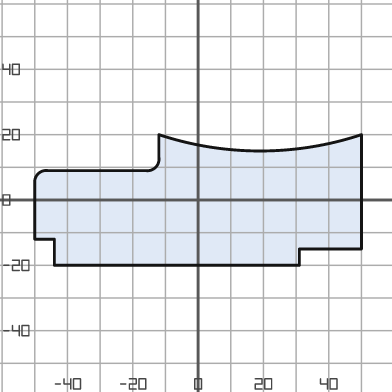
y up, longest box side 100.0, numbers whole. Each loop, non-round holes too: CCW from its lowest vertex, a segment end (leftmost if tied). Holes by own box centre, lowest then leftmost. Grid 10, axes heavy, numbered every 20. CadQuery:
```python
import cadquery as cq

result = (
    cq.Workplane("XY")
    .moveTo(-44.0, -20.0)
    .lineTo(31.0, -20.0)
    .lineTo(31.0, -15.0)
    .lineTo(50.0, -15.0)
    .lineTo(50.0, 20.0)
    .threePointArc((19.0, 15.0), (-12.0, 20.0))
    .lineTo(-12.0, 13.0)
    .threePointArc((-13.0, 10.0), (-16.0, 9.0))
    .lineTo(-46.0, 9.0)
    .threePointArc((-49.0, 8.0), (-50.0, 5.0))
    .lineTo(-50.0, -12.0)
    .lineTo(-44.0, -12.0)
    .close()
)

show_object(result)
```